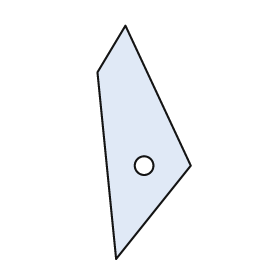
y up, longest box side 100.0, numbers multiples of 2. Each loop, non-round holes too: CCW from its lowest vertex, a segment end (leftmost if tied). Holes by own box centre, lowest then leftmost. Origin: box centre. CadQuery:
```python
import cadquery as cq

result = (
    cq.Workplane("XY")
    .moveTo(-12.0, -50.0)
    .lineTo(20.0, -10.0)
    .lineTo(-8.0, 50.0)
    .lineTo(-20.0, 30.0)
    .close()
    .moveTo(0.0, -10.0)
    .circle(4.0)
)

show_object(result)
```